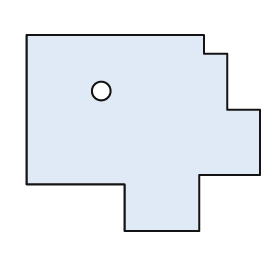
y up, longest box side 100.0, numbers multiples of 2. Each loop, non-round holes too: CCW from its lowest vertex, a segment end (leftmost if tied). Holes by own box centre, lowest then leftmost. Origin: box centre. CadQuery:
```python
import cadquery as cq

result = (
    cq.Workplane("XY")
    .moveTo(-8.0, -42.0)
    .lineTo(24.0, -42.0)
    .lineTo(24.0, -18.0)
    .lineTo(50.0, -18.0)
    .lineTo(50.0, 10.0)
    .lineTo(36.0, 10.0)
    .lineTo(36.0, 34.0)
    .lineTo(26.0, 34.0)
    .lineTo(26.0, 42.0)
    .lineTo(-50.0, 42.0)
    .lineTo(-50.0, -22.0)
    .lineTo(-8.0, -22.0)
    .close()
    .moveTo(-18.0, 18.0)
    .circle(4.0)
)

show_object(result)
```